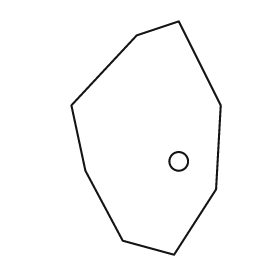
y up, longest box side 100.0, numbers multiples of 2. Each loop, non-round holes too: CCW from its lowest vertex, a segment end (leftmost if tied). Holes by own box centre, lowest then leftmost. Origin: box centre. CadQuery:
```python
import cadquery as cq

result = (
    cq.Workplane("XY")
    .moveTo(12.0, -50.0)
    .lineTo(30.0, -22.0)
    .lineTo(32.0, 14.0)
    .lineTo(14.0, 50.0)
    .lineTo(-4.0, 44.0)
    .lineTo(-32.0, 14.0)
    .lineTo(-26.0, -14.0)
    .lineTo(-10.0, -44.0)
    .close()
    .moveTo(14.0, -10.0)
    .circle(4.0)
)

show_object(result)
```